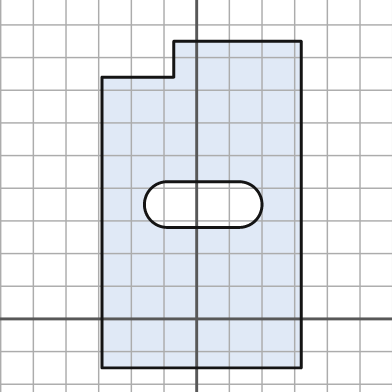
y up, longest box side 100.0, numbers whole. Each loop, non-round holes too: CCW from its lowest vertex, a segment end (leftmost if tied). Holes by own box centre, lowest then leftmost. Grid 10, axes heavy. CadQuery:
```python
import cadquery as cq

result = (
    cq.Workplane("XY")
    .moveTo(-29.0, -15.0)
    .lineTo(32.0, -15.0)
    .lineTo(32.0, 85.0)
    .lineTo(-7.0, 85.0)
    .lineTo(-7.0, 74.0)
    .lineTo(-29.0, 74.0)
    .close()
    .moveTo(-9.0, 28.0)
    .lineTo(13.0, 28.0)
    .threePointArc((20.0, 35.0), (13.0, 42.0))
    .lineTo(-9.0, 42.0)
    .threePointArc((-16.0, 35.0), (-9.0, 28.0))
    .close()
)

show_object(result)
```